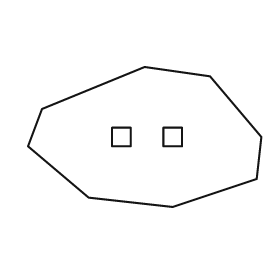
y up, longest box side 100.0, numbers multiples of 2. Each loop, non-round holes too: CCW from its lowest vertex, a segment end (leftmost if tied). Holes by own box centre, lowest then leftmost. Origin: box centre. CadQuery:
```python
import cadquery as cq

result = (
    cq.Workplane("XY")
    .moveTo(12.0, -30.0)
    .lineTo(48.0, -18.0)
    .lineTo(50.0, 0.0)
    .lineTo(28.0, 26.0)
    .lineTo(0.0, 30.0)
    .lineTo(-44.0, 12.0)
    .lineTo(-50.0, -4.0)
    .lineTo(-24.0, -26.0)
    .close()
    .moveTo(-14.0, -4.0)
    .lineTo(-6.0, -4.0)
    .lineTo(-6.0, 4.0)
    .lineTo(-14.0, 4.0)
    .close()
    .moveTo(8.0, -4.0)
    .lineTo(16.0, -4.0)
    .lineTo(16.0, 4.0)
    .lineTo(8.0, 4.0)
    .close()
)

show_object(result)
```